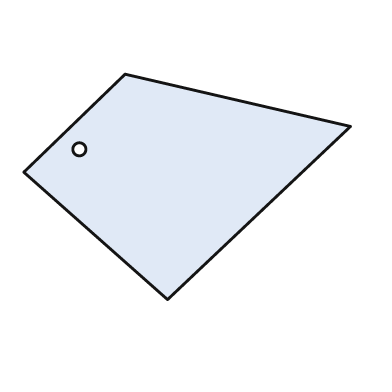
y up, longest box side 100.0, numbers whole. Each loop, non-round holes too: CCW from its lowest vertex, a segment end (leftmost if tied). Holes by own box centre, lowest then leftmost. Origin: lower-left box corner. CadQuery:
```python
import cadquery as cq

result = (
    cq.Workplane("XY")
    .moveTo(44.0, 0.0)
    .lineTo(100.0, 53.0)
    .lineTo(31.0, 69.0)
    .lineTo(0.0, 39.0)
    .close()
    .moveTo(17.0, 46.0)
    .circle(2.0)
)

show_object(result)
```